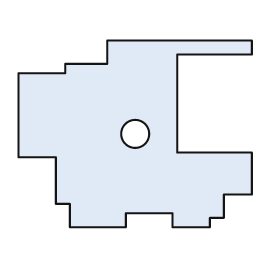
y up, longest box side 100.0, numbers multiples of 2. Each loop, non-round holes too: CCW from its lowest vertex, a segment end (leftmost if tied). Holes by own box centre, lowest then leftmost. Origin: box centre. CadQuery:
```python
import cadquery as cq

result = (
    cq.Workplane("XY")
    .moveTo(-28.0, -40.0)
    .lineTo(-4.0, -40.0)
    .lineTo(-4.0, -34.0)
    .lineTo(16.0, -34.0)
    .lineTo(16.0, -40.0)
    .lineTo(32.0, -40.0)
    .lineTo(32.0, -36.0)
    .lineTo(38.0, -36.0)
    .lineTo(38.0, -26.0)
    .lineTo(50.0, -26.0)
    .lineTo(50.0, -8.0)
    .lineTo(18.0, -8.0)
    .lineTo(18.0, 34.0)
    .lineTo(50.0, 34.0)
    .lineTo(50.0, 40.0)
    .lineTo(-12.0, 40.0)
    .lineTo(-12.0, 30.0)
    .lineTo(-30.0, 30.0)
    .lineTo(-30.0, 26.0)
    .lineTo(-50.0, 26.0)
    .lineTo(-50.0, -10.0)
    .lineTo(-34.0, -10.0)
    .lineTo(-34.0, -30.0)
    .lineTo(-28.0, -30.0)
    .close()
    .moveTo(0.0, 0.0)
    .circle(6.0)
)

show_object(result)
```